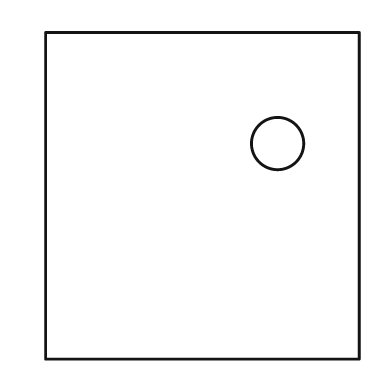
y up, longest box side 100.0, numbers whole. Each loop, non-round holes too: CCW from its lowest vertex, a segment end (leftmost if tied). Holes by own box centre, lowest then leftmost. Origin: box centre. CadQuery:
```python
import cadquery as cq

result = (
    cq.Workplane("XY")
    .moveTo(-48.0, -50.0)
    .lineTo(48.0, -50.0)
    .lineTo(48.0, 50.0)
    .lineTo(-48.0, 50.0)
    .close()
    .moveTo(23.0, 16.0)
    .circle(8.0)
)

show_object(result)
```